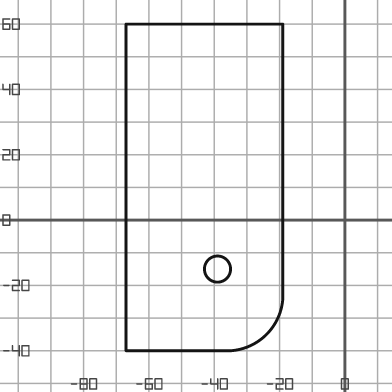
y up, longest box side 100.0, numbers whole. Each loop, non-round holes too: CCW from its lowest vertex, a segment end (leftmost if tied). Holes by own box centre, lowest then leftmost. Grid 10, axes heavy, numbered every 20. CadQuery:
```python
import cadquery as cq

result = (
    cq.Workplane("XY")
    .moveTo(-67.0, -40.0)
    .lineTo(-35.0, -40.0)
    .threePointArc((-24.0, -35.0), (-19.0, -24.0))
    .lineTo(-19.0, 60.0)
    .lineTo(-67.0, 60.0)
    .close()
    .moveTo(-39.0, -15.0)
    .circle(4.0)
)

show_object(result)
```